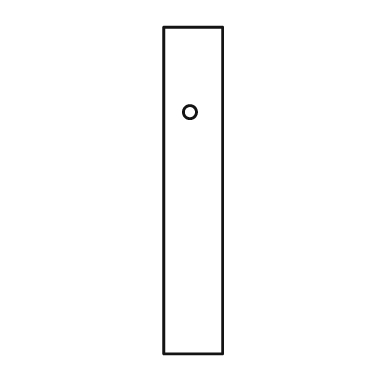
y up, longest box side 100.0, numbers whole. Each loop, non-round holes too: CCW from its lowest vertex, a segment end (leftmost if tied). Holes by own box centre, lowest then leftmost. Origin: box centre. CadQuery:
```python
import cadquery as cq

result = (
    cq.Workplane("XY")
    .moveTo(-9.0, -50.0)
    .lineTo(9.0, -50.0)
    .lineTo(9.0, 50.0)
    .lineTo(-9.0, 50.0)
    .close()
    .moveTo(-1.0, 24.0)
    .circle(2.0)
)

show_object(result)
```